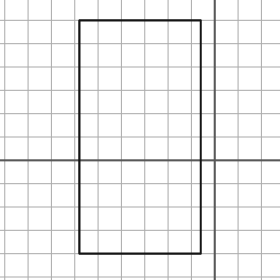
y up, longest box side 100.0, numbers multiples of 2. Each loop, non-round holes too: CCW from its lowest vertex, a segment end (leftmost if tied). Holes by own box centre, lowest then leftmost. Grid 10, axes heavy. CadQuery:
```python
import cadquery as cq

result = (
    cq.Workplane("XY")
    .moveTo(-58.0, -40.0)
    .lineTo(-6.0, -40.0)
    .lineTo(-6.0, 60.0)
    .lineTo(-58.0, 60.0)
    .close()
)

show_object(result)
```